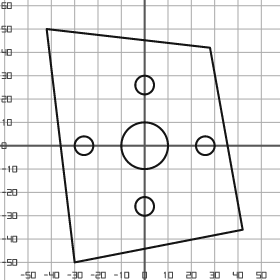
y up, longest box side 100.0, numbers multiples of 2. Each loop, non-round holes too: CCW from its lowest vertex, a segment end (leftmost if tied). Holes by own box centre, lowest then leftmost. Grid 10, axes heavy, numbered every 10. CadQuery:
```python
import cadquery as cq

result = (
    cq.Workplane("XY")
    .moveTo(-30.0, -50.0)
    .lineTo(42.0, -36.0)
    .lineTo(28.0, 42.0)
    .lineTo(-42.0, 50.0)
    .close()
    .moveTo(0.0, -26.0)
    .circle(4.0)
    .moveTo(-26.0, 0.0)
    .circle(4.0)
    .moveTo(0.0, 0.0)
    .circle(10.0)
    .moveTo(26.0, 0.0)
    .circle(4.0)
    .moveTo(0.0, 26.0)
    .circle(4.0)
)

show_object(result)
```